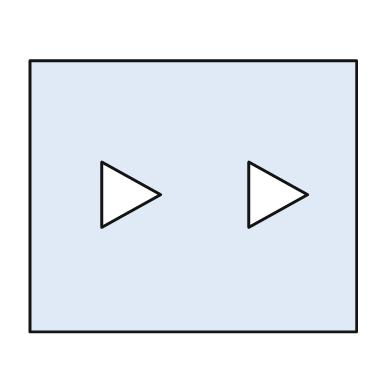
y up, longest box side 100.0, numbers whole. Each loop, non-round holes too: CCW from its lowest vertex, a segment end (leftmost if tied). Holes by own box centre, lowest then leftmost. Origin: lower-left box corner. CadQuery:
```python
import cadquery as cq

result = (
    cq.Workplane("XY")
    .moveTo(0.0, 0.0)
    .lineTo(100.0, 0.0)
    .lineTo(100.0, 83.0)
    .lineTo(0.0, 83.0)
    .close()
    .moveTo(22.0, 32.0)
    .lineTo(40.0, 42.0)
    .lineTo(22.0, 52.0)
    .close()
    .moveTo(67.0, 32.0)
    .lineTo(85.0, 42.0)
    .lineTo(67.0, 52.0)
    .close()
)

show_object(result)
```